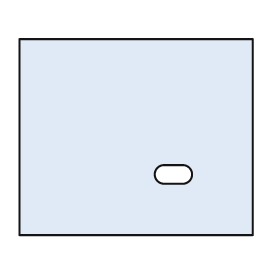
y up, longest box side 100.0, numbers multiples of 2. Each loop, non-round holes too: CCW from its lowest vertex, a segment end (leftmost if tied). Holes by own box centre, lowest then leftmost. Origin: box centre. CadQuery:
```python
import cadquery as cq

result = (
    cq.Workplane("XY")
    .moveTo(-50.0, -42.0)
    .lineTo(50.0, -42.0)
    .lineTo(50.0, 42.0)
    .lineTo(-50.0, 42.0)
    .close()
    .moveTo(12.0, -20.0)
    .lineTo(20.0, -20.0)
    .threePointArc((24.0, -16.0), (20.0, -12.0))
    .lineTo(12.0, -12.0)
    .threePointArc((8.0, -16.0), (12.0, -20.0))
    .close()
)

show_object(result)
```